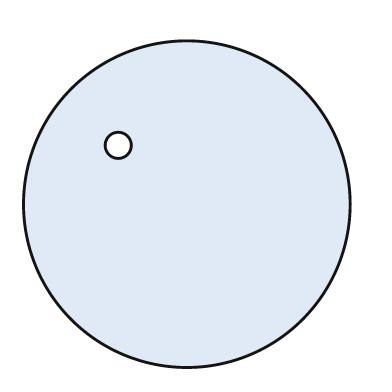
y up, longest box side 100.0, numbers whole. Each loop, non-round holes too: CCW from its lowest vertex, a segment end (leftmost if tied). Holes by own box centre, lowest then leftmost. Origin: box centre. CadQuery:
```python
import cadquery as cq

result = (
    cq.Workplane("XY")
    .moveTo(0.0, 0.0)
    .circle(50.0)
    .moveTo(-21.0, 18.0)
    .circle(4.0)
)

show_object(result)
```